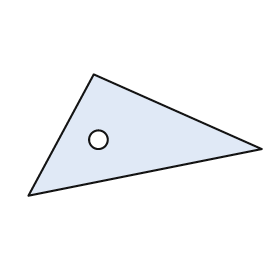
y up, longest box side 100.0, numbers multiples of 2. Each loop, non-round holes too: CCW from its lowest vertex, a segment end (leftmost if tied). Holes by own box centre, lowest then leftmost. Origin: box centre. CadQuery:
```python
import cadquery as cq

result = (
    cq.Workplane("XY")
    .moveTo(-50.0, -26.0)
    .lineTo(50.0, -6.0)
    .lineTo(-22.0, 26.0)
    .close()
    .moveTo(-20.0, -2.0)
    .circle(4.0)
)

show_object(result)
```